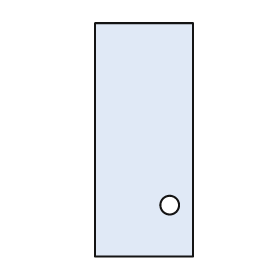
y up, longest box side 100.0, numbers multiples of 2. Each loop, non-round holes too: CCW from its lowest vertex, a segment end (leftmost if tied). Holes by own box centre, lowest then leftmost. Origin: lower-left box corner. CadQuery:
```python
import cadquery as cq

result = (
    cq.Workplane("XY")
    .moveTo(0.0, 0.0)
    .lineTo(42.0, 0.0)
    .lineTo(42.0, 100.0)
    .lineTo(0.0, 100.0)
    .close()
    .moveTo(32.0, 22.0)
    .circle(4.0)
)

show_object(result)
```